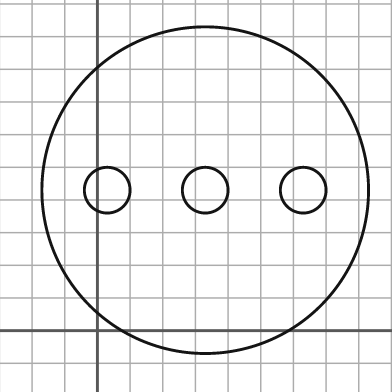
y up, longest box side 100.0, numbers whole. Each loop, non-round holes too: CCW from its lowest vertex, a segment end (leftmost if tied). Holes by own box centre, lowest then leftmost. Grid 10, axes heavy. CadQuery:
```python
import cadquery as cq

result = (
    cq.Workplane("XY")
    .moveTo(33.0, 43.0)
    .circle(50.0)
    .moveTo(3.0, 43.0)
    .circle(7.0)
    .moveTo(33.0, 43.0)
    .circle(7.0)
    .moveTo(63.0, 43.0)
    .circle(7.0)
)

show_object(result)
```